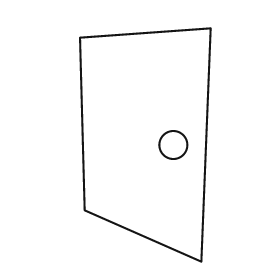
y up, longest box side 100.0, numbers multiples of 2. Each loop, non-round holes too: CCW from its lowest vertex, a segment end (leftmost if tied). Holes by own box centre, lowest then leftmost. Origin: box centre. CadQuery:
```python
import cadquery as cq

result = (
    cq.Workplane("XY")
    .moveTo(24.0, -50.0)
    .lineTo(28.0, 50.0)
    .lineTo(-28.0, 46.0)
    .lineTo(-26.0, -28.0)
    .close()
    .moveTo(12.0, 0.0)
    .circle(6.0)
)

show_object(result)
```